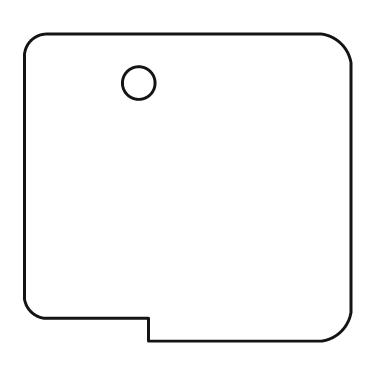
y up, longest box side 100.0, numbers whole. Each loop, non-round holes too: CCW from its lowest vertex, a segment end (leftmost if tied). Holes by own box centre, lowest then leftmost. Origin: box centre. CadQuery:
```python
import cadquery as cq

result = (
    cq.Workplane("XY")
    .moveTo(-12.0, -47.0)
    .lineTo(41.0, -47.0)
    .threePointArc((47.0, -44.0), (50.0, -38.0))
    .lineTo(50.0, 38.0)
    .threePointArc((47.0, 44.0), (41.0, 47.0))
    .lineTo(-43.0, 47.0)
    .threePointArc((-48.0, 45.0), (-50.0, 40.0))
    .lineTo(-50.0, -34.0)
    .threePointArc((-48.0, -38.0), (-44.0, -40.0))
    .lineTo(-12.0, -40.0)
    .close()
    .moveTo(-15.0, 32.0)
    .circle(5.0)
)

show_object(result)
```